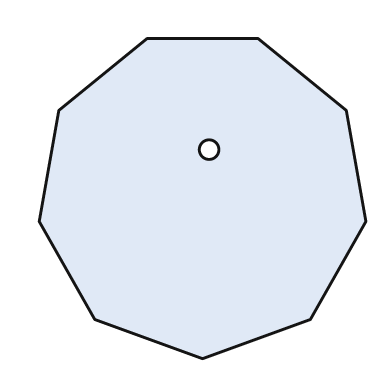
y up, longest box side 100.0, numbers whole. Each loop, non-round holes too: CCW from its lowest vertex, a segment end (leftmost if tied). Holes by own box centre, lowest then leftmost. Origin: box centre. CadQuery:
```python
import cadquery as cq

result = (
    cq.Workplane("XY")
    .moveTo(0.0, -49.0)
    .lineTo(33.0, -37.0)
    .lineTo(50.0, -7.0)
    .lineTo(44.0, 27.0)
    .lineTo(17.0, 49.0)
    .lineTo(-17.0, 49.0)
    .lineTo(-44.0, 27.0)
    .lineTo(-50.0, -7.0)
    .lineTo(-33.0, -37.0)
    .close()
    .moveTo(2.0, 15.0)
    .circle(3.0)
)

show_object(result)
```